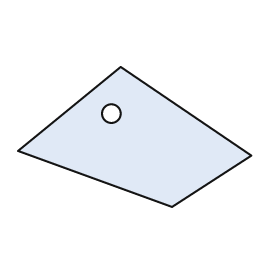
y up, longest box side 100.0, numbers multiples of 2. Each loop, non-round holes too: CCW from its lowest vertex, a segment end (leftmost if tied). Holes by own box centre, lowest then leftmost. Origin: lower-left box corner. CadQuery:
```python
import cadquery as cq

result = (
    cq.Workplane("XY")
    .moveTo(66.0, 0.0)
    .lineTo(100.0, 22.0)
    .lineTo(44.0, 60.0)
    .lineTo(0.0, 24.0)
    .close()
    .moveTo(40.0, 40.0)
    .circle(4.0)
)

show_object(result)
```